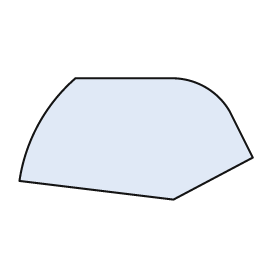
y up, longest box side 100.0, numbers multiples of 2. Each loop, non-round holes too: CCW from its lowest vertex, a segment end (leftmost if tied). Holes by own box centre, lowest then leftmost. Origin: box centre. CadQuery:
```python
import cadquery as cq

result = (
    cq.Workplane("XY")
    .moveTo(16.0, -26.0)
    .lineTo(50.0, -8.0)
    .lineTo(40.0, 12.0)
    .threePointArc((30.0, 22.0), (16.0, 26.0))
    .lineTo(-26.0, 26.0)
    .threePointArc((-42.0, 6.0), (-50.0, -18.0))
    .close()
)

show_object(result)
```